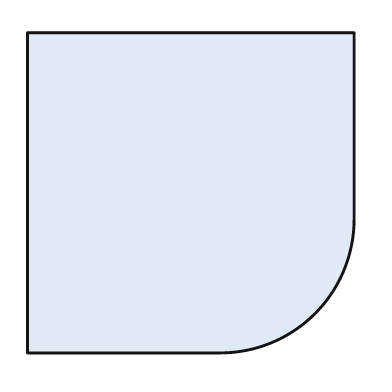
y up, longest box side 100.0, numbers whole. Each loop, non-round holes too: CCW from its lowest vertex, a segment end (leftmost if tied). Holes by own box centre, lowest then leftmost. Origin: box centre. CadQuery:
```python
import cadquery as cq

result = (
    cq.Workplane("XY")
    .moveTo(-50.0, -49.0)
    .lineTo(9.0, -49.0)
    .threePointArc((38.0, -37.0), (50.0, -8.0))
    .lineTo(50.0, 49.0)
    .lineTo(-50.0, 49.0)
    .close()
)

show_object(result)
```